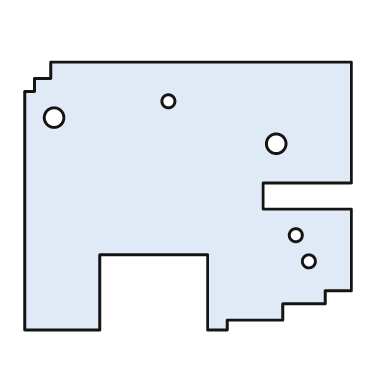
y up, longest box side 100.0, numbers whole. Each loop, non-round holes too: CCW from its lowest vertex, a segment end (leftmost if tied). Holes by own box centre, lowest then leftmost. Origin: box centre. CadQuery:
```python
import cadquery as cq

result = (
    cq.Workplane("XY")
    .moveTo(-50.0, -41.0)
    .lineTo(-27.0, -41.0)
    .lineTo(-27.0, -18.0)
    .lineTo(6.0, -18.0)
    .lineTo(6.0, -41.0)
    .lineTo(12.0, -41.0)
    .lineTo(12.0, -38.0)
    .lineTo(29.0, -38.0)
    .lineTo(29.0, -33.0)
    .lineTo(42.0, -33.0)
    .lineTo(42.0, -29.0)
    .lineTo(50.0, -29.0)
    .lineTo(50.0, -4.0)
    .lineTo(23.0, -4.0)
    .lineTo(23.0, 4.0)
    .lineTo(50.0, 4.0)
    .lineTo(50.0, 41.0)
    .lineTo(-42.0, 41.0)
    .lineTo(-42.0, 36.0)
    .lineTo(-47.0, 36.0)
    .lineTo(-47.0, 32.0)
    .lineTo(-50.0, 32.0)
    .close()
    .moveTo(37.0, -20.0)
    .circle(2.0)
    .moveTo(33.0, -12.0)
    .circle(2.0)
    .moveTo(27.0, 16.0)
    .circle(3.0)
    .moveTo(-41.0, 24.0)
    .circle(3.0)
    .moveTo(-6.0, 29.0)
    .circle(2.0)
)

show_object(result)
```